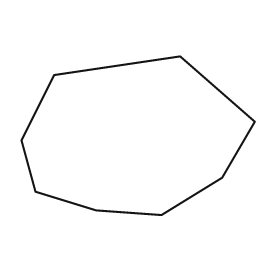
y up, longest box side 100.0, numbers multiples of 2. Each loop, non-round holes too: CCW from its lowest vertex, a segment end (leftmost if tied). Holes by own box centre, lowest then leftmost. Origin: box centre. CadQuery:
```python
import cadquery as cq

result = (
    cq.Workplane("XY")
    .moveTo(10.0, -34.0)
    .lineTo(36.0, -18.0)
    .lineTo(50.0, 6.0)
    .lineTo(18.0, 34.0)
    .lineTo(-36.0, 26.0)
    .lineTo(-50.0, -2.0)
    .lineTo(-44.0, -24.0)
    .lineTo(-18.0, -32.0)
    .close()
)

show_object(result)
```